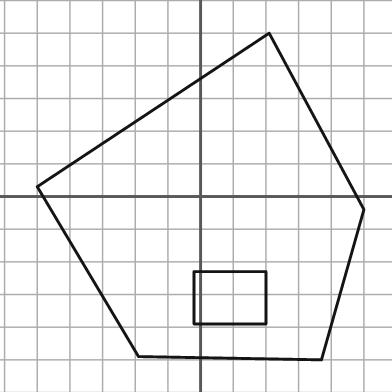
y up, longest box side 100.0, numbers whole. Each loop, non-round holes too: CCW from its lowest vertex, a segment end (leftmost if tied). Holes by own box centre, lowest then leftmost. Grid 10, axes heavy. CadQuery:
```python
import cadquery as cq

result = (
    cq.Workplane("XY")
    .moveTo(37.0, -50.0)
    .lineTo(50.0, -4.0)
    .lineTo(21.0, 50.0)
    .lineTo(-50.0, 3.0)
    .lineTo(-19.0, -49.0)
    .close()
    .moveTo(-2.0, -39.0)
    .lineTo(20.0, -39.0)
    .lineTo(20.0, -23.0)
    .lineTo(-2.0, -23.0)
    .close()
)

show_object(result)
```